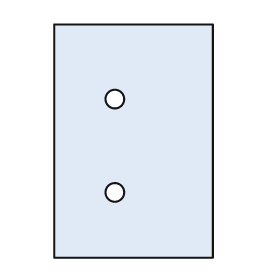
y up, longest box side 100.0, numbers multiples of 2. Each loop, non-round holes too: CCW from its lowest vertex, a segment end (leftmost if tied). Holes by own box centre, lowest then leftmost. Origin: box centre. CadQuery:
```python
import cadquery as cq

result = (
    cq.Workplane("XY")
    .moveTo(-34.0, -50.0)
    .lineTo(34.0, -50.0)
    .lineTo(34.0, 50.0)
    .lineTo(-34.0, 50.0)
    .close()
    .moveTo(-8.0, -22.0)
    .circle(4.0)
    .moveTo(-8.0, 18.0)
    .circle(4.0)
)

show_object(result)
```